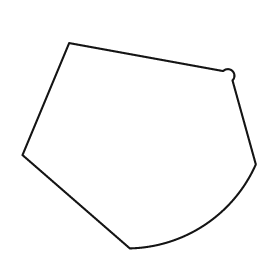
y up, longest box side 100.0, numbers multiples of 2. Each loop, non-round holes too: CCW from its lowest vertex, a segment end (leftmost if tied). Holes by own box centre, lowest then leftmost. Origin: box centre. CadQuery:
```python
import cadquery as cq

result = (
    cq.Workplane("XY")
    .moveTo(-4.0, -44.0)
    .threePointArc((28.0, -34.0), (50.0, -8.0))
    .lineTo(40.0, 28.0)
    .threePointArc((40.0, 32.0), (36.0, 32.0))
    .lineTo(-30.0, 44.0)
    .lineTo(-50.0, -4.0)
    .close()
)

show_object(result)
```